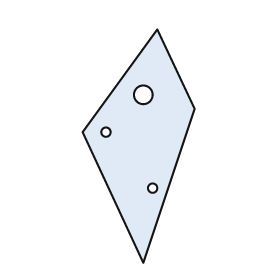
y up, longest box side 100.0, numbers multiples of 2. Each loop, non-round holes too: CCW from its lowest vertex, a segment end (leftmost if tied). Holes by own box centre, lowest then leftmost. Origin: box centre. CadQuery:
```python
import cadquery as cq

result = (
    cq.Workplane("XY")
    .moveTo(2.0, -50.0)
    .lineTo(24.0, 16.0)
    .lineTo(8.0, 50.0)
    .lineTo(-24.0, 6.0)
    .close()
    .moveTo(6.0, -18.0)
    .circle(2.0)
    .moveTo(-14.0, 6.0)
    .circle(2.0)
    .moveTo(2.0, 22.0)
    .circle(4.0)
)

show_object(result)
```